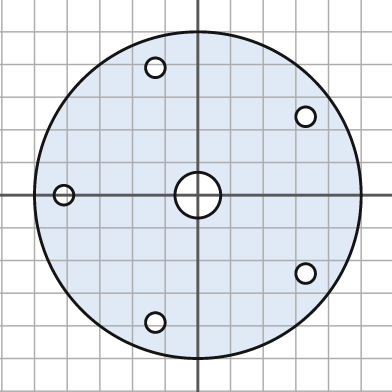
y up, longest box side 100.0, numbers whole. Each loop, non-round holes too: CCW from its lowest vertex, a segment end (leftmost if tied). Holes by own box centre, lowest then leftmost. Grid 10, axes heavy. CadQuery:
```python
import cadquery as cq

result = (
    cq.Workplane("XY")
    .moveTo(0.0, 0.0)
    .circle(50.0)
    .moveTo(-13.0, -39.0)
    .circle(3.0)
    .moveTo(33.0, -24.0)
    .circle(3.0)
    .moveTo(-41.0, 0.0)
    .circle(3.0)
    .moveTo(0.0, 0.0)
    .circle(7.0)
    .moveTo(33.0, 24.0)
    .circle(3.0)
    .moveTo(-13.0, 39.0)
    .circle(3.0)
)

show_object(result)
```